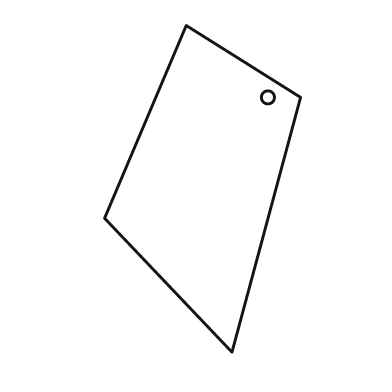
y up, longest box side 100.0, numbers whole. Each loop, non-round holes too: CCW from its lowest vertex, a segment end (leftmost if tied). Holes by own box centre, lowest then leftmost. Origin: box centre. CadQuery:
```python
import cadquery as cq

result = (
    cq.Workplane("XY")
    .moveTo(9.0, -50.0)
    .lineTo(30.0, 28.0)
    .lineTo(-5.0, 50.0)
    .lineTo(-30.0, -9.0)
    .close()
    .moveTo(20.0, 28.0)
    .circle(2.0)
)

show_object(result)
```